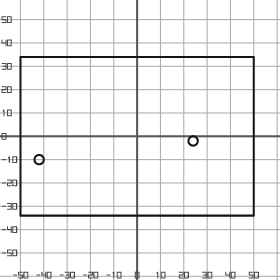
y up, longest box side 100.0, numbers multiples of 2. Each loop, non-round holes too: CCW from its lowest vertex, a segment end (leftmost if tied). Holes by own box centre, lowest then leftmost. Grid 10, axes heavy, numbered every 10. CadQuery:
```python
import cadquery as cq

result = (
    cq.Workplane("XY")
    .moveTo(-50.0, -34.0)
    .lineTo(50.0, -34.0)
    .lineTo(50.0, 34.0)
    .lineTo(-50.0, 34.0)
    .close()
    .moveTo(-42.0, -10.0)
    .circle(2.0)
    .moveTo(24.0, -2.0)
    .circle(2.0)
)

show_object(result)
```